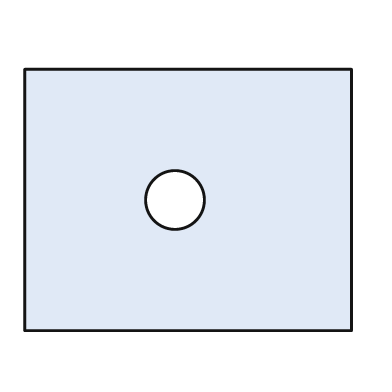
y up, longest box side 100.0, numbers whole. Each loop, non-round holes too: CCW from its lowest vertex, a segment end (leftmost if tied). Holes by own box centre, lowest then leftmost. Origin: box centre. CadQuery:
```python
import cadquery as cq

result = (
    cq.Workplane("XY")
    .moveTo(-50.0, -40.0)
    .lineTo(50.0, -40.0)
    .lineTo(50.0, 40.0)
    .lineTo(-50.0, 40.0)
    .close()
    .moveTo(-4.0, 0.0)
    .circle(9.0)
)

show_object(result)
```